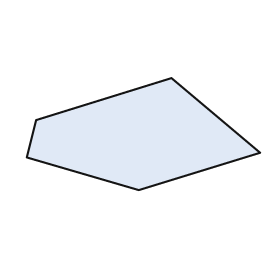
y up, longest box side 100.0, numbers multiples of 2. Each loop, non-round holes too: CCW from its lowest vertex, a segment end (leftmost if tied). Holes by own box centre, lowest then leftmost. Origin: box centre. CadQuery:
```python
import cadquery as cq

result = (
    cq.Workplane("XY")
    .moveTo(-2.0, -24.0)
    .lineTo(50.0, -8.0)
    .lineTo(12.0, 24.0)
    .lineTo(-46.0, 6.0)
    .lineTo(-50.0, -10.0)
    .close()
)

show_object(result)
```